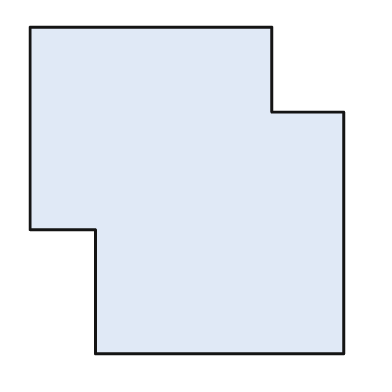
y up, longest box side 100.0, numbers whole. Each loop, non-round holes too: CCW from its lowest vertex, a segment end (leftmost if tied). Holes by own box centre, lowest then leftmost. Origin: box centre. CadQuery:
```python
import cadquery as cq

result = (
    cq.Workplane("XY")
    .moveTo(-28.0, -50.0)
    .lineTo(48.0, -50.0)
    .lineTo(48.0, 24.0)
    .lineTo(26.0, 24.0)
    .lineTo(26.0, 50.0)
    .lineTo(-48.0, 50.0)
    .lineTo(-48.0, -12.0)
    .lineTo(-28.0, -12.0)
    .close()
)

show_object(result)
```